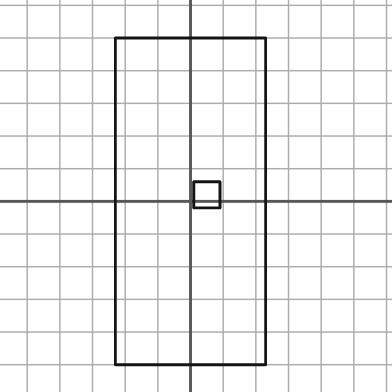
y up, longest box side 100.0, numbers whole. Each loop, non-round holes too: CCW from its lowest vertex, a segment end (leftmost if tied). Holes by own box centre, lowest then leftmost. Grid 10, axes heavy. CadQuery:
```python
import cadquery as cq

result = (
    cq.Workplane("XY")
    .moveTo(-23.0, -50.0)
    .lineTo(23.0, -50.0)
    .lineTo(23.0, 50.0)
    .lineTo(-23.0, 50.0)
    .close()
    .moveTo(1.0, -2.0)
    .lineTo(9.0, -2.0)
    .lineTo(9.0, 6.0)
    .lineTo(1.0, 6.0)
    .close()
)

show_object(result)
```